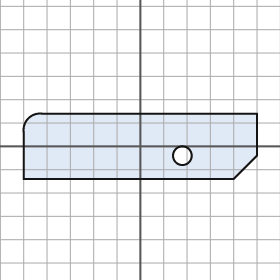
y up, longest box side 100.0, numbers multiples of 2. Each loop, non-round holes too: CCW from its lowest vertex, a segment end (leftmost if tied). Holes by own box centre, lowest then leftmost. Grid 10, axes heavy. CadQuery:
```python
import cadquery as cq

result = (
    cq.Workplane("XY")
    .moveTo(-50.0, -14.0)
    .lineTo(40.0, -14.0)
    .lineTo(50.0, -4.0)
    .lineTo(50.0, 14.0)
    .lineTo(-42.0, 14.0)
    .threePointArc((-48.0, 12.0), (-50.0, 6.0))
    .close()
    .moveTo(18.0, -4.0)
    .circle(4.0)
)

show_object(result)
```